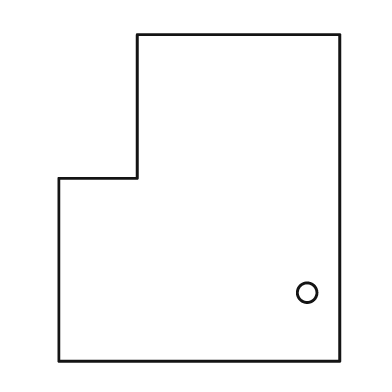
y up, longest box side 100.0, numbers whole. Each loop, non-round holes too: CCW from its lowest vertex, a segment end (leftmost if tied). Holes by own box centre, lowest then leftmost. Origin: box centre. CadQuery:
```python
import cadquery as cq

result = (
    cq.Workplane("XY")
    .moveTo(-43.0, -50.0)
    .lineTo(43.0, -50.0)
    .lineTo(43.0, 50.0)
    .lineTo(-19.0, 50.0)
    .lineTo(-19.0, 6.0)
    .lineTo(-43.0, 6.0)
    .close()
    .moveTo(33.0, -29.0)
    .circle(3.0)
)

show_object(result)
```